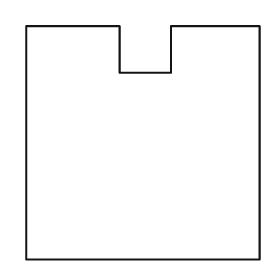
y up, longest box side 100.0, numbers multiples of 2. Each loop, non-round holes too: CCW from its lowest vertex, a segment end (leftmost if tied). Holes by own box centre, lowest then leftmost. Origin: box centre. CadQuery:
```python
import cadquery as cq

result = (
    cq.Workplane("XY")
    .moveTo(-50.0, -50.0)
    .lineTo(50.0, -50.0)
    .lineTo(50.0, 50.0)
    .lineTo(12.0, 50.0)
    .lineTo(12.0, 30.0)
    .lineTo(-10.0, 30.0)
    .lineTo(-10.0, 50.0)
    .lineTo(-50.0, 50.0)
    .close()
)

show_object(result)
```